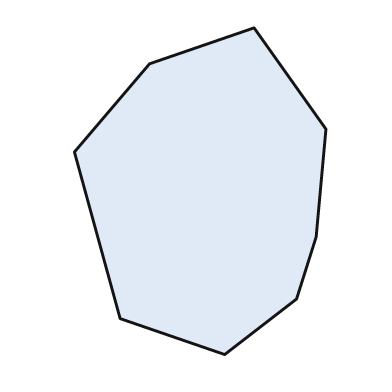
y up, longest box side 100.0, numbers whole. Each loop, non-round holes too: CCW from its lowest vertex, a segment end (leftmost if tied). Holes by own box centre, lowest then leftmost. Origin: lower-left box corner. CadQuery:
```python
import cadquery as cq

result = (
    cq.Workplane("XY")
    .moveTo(46.0, 0.0)
    .lineTo(68.0, 17.0)
    .lineTo(74.0, 36.0)
    .lineTo(77.0, 69.0)
    .lineTo(55.0, 100.0)
    .lineTo(23.0, 89.0)
    .lineTo(0.0, 62.0)
    .lineTo(14.0, 11.0)
    .close()
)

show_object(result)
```